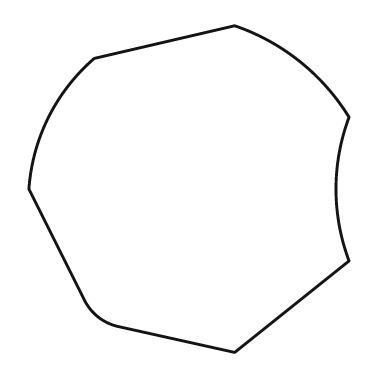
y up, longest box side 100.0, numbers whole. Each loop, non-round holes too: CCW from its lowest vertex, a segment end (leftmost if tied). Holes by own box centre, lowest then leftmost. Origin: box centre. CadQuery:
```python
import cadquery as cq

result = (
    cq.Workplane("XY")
    .moveTo(14.0, -50.0)
    .lineTo(49.0, -22.0)
    .threePointArc((45.0, 0.0), (49.0, 22.0))
    .threePointArc((34.0, 39.0), (14.0, 50.0))
    .lineTo(-29.0, 40.0)
    .threePointArc((-43.0, 22.0), (-49.0, 0.0))
    .lineTo(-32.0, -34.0)
    .threePointArc((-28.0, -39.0), (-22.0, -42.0))
    .close()
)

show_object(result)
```